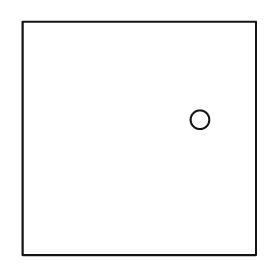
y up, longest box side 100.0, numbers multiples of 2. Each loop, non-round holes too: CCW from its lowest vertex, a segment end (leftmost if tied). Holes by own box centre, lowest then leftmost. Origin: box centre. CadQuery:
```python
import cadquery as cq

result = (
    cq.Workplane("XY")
    .moveTo(-50.0, -50.0)
    .lineTo(50.0, -50.0)
    .lineTo(50.0, 50.0)
    .lineTo(-50.0, 50.0)
    .close()
    .moveTo(26.0, 8.0)
    .circle(4.0)
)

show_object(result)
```